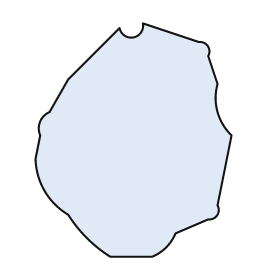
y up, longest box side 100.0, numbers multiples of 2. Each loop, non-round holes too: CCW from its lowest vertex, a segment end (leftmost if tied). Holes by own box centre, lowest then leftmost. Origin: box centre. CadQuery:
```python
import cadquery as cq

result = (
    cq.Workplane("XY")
    .moveTo(-10.0, -50.0)
    .lineTo(8.0, -50.0)
    .threePointArc((14.0, -46.0), (18.0, -40.0))
    .lineTo(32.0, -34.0)
    .threePointArc((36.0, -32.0), (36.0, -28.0))
    .lineTo(42.0, 2.0)
    .threePointArc((36.0, 12.0), (36.0, 24.0))
    .lineTo(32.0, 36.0)
    .threePointArc((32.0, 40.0), (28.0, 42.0))
    .lineTo(4.0, 50.0)
    .threePointArc((0.0, 44.0), (-6.0, 48.0))
    .lineTo(-28.0, 26.0)
    .lineTo(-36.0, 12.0)
    .threePointArc((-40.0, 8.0), (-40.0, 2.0))
    .lineTo(-42.0, -8.0)
    .threePointArc((-38.0, -22.0), (-28.0, -32.0))
    .threePointArc((-20.0, -42.0), (-10.0, -50.0))
    .close()
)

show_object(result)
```